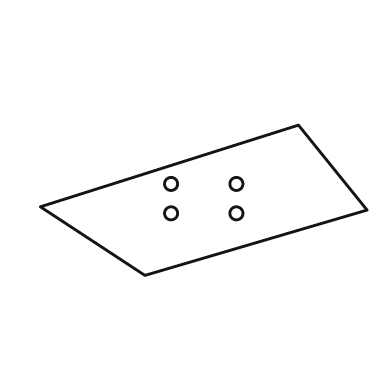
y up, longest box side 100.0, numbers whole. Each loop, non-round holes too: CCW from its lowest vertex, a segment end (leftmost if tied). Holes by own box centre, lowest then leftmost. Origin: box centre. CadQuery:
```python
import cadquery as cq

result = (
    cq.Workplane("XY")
    .moveTo(-18.0, -23.0)
    .lineTo(50.0, -3.0)
    .lineTo(29.0, 23.0)
    .lineTo(-50.0, -2.0)
    .close()
    .moveTo(-10.0, -4.0)
    .circle(2.0)
    .moveTo(10.0, -4.0)
    .circle(2.0)
    .moveTo(-10.0, 5.0)
    .circle(2.0)
    .moveTo(10.0, 5.0)
    .circle(2.0)
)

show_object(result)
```